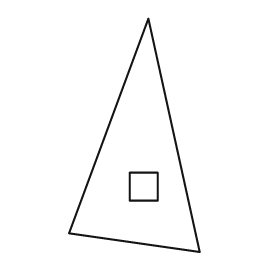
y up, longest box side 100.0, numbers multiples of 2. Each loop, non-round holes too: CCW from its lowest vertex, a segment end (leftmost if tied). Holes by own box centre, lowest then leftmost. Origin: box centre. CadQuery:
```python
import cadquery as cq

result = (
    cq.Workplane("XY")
    .moveTo(28.0, -50.0)
    .lineTo(6.0, 50.0)
    .lineTo(-28.0, -42.0)
    .close()
    .moveTo(-2.0, -28.0)
    .lineTo(10.0, -28.0)
    .lineTo(10.0, -16.0)
    .lineTo(-2.0, -16.0)
    .close()
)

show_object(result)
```